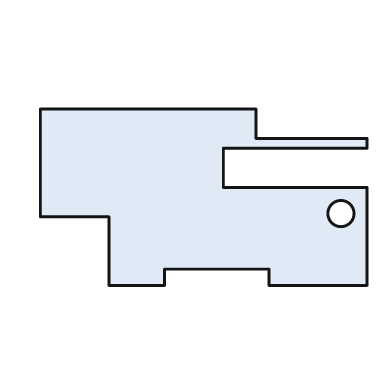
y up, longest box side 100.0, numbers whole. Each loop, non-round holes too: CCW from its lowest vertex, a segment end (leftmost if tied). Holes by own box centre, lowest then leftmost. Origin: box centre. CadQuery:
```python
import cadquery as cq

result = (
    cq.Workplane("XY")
    .moveTo(-29.0, -27.0)
    .lineTo(-12.0, -27.0)
    .lineTo(-12.0, -22.0)
    .lineTo(20.0, -22.0)
    .lineTo(20.0, -27.0)
    .lineTo(50.0, -27.0)
    .lineTo(50.0, 3.0)
    .lineTo(6.0, 3.0)
    .lineTo(6.0, 15.0)
    .lineTo(50.0, 15.0)
    .lineTo(50.0, 18.0)
    .lineTo(16.0, 18.0)
    .lineTo(16.0, 27.0)
    .lineTo(-50.0, 27.0)
    .lineTo(-50.0, -6.0)
    .lineTo(-29.0, -6.0)
    .close()
    .moveTo(42.0, -5.0)
    .circle(4.0)
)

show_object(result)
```